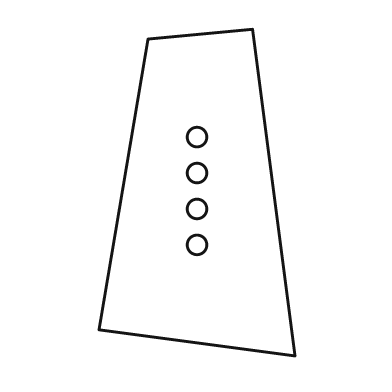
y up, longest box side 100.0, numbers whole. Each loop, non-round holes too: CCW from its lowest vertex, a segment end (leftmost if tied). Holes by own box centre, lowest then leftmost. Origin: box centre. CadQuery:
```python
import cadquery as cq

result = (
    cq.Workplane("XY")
    .moveTo(30.0, -50.0)
    .lineTo(17.0, 50.0)
    .lineTo(-15.0, 47.0)
    .lineTo(-30.0, -42.0)
    .close()
    .moveTo(0.0, -16.0)
    .circle(3.0)
    .moveTo(0.0, -5.0)
    .circle(3.0)
    .moveTo(0.0, 6.0)
    .circle(3.0)
    .moveTo(0.0, 17.0)
    .circle(3.0)
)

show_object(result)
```